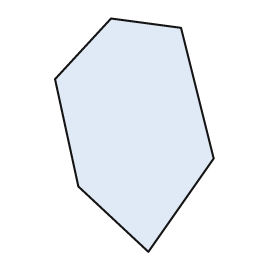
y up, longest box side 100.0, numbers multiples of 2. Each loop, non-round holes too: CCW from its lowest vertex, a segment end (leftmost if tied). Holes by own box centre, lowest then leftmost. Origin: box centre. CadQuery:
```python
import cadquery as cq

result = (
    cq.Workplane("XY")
    .moveTo(6.0, -50.0)
    .lineTo(34.0, -10.0)
    .lineTo(20.0, 46.0)
    .lineTo(-10.0, 50.0)
    .lineTo(-34.0, 24.0)
    .lineTo(-24.0, -22.0)
    .close()
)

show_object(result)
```